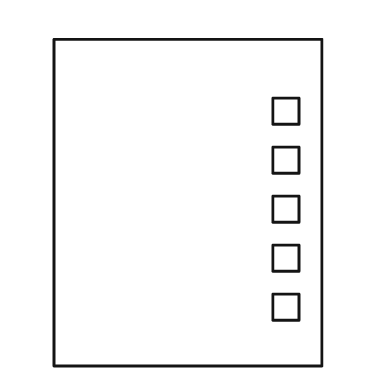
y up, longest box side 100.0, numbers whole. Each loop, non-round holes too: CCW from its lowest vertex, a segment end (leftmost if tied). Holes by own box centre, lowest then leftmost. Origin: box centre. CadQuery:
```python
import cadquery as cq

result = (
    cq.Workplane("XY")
    .moveTo(-41.0, -50.0)
    .lineTo(41.0, -50.0)
    .lineTo(41.0, 50.0)
    .lineTo(-41.0, 50.0)
    .close()
    .moveTo(26.0, -36.0)
    .lineTo(34.0, -36.0)
    .lineTo(34.0, -28.0)
    .lineTo(26.0, -28.0)
    .close()
    .moveTo(26.0, -21.0)
    .lineTo(34.0, -21.0)
    .lineTo(34.0, -13.0)
    .lineTo(26.0, -13.0)
    .close()
    .moveTo(26.0, -6.0)
    .lineTo(34.0, -6.0)
    .lineTo(34.0, 2.0)
    .lineTo(26.0, 2.0)
    .close()
    .moveTo(26.0, 9.0)
    .lineTo(34.0, 9.0)
    .lineTo(34.0, 17.0)
    .lineTo(26.0, 17.0)
    .close()
    .moveTo(26.0, 24.0)
    .lineTo(34.0, 24.0)
    .lineTo(34.0, 32.0)
    .lineTo(26.0, 32.0)
    .close()
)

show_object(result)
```